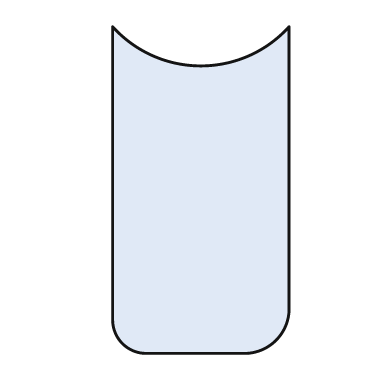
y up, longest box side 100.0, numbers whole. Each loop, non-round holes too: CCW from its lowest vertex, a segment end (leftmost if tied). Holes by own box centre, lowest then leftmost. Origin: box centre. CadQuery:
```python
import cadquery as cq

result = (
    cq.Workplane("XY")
    .moveTo(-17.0, -50.0)
    .lineTo(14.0, -50.0)
    .threePointArc((23.0, -46.0), (27.0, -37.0))
    .lineTo(27.0, 50.0)
    .threePointArc((0.0, 38.0), (-27.0, 50.0))
    .lineTo(-27.0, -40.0)
    .threePointArc((-24.0, -47.0), (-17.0, -50.0))
    .close()
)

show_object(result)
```